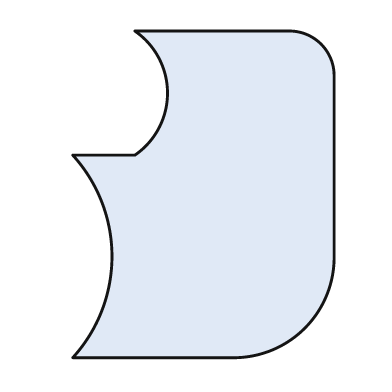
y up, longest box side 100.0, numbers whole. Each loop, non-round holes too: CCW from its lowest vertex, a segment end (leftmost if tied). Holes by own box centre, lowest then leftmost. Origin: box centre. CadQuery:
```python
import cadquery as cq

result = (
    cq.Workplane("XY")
    .moveTo(-40.0, -50.0)
    .lineTo(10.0, -50.0)
    .threePointArc((31.0, -41.0), (40.0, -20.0))
    .lineTo(40.0, 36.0)
    .threePointArc((36.0, 46.0), (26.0, 50.0))
    .lineTo(-21.0, 50.0)
    .threePointArc((-11.0, 31.0), (-21.0, 12.0))
    .lineTo(-40.0, 12.0)
    .threePointArc((-28.0, -19.0), (-40.0, -50.0))
    .close()
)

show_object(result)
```